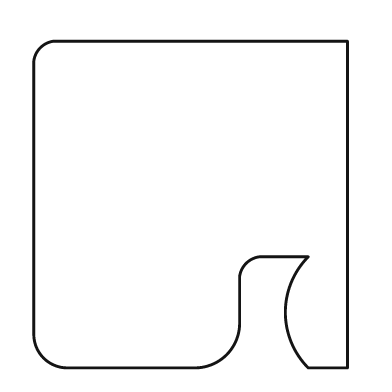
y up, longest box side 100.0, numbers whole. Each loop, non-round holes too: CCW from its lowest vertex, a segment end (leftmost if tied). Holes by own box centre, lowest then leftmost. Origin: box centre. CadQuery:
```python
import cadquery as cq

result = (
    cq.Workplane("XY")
    .moveTo(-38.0, -50.0)
    .lineTo(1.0, -50.0)
    .threePointArc((11.0, -46.0), (15.0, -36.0))
    .lineTo(15.0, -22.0)
    .threePointArc((17.0, -18.0), (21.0, -16.0))
    .lineTo(36.0, -16.0)
    .threePointArc((29.0, -33.0), (36.0, -50.0))
    .lineTo(48.0, -50.0)
    .lineTo(48.0, 50.0)
    .lineTo(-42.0, 50.0)
    .threePointArc((-46.0, 48.0), (-48.0, 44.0))
    .lineTo(-48.0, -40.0)
    .threePointArc((-45.0, -47.0), (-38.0, -50.0))
    .close()
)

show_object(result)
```